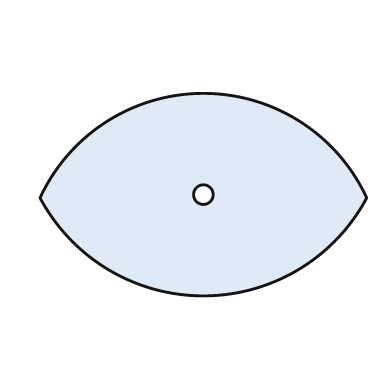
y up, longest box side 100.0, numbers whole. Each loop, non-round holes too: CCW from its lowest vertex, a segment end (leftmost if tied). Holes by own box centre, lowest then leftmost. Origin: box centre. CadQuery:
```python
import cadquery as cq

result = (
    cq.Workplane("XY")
    .moveTo(-50.0, -1.0)
    .threePointArc((0.0, -31.0), (50.0, -1.0))
    .threePointArc((0.0, 31.0), (-50.0, -1.0))
    .close()
    .moveTo(0.0, 0.0)
    .circle(3.0)
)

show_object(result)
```